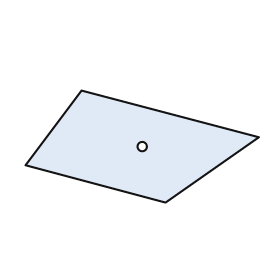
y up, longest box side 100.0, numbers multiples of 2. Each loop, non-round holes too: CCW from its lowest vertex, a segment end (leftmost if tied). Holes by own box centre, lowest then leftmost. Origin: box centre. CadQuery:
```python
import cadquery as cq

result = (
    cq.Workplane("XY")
    .moveTo(10.0, -24.0)
    .lineTo(50.0, 4.0)
    .lineTo(-26.0, 24.0)
    .lineTo(-50.0, -8.0)
    .close()
    .moveTo(0.0, 0.0)
    .circle(2.0)
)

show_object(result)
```